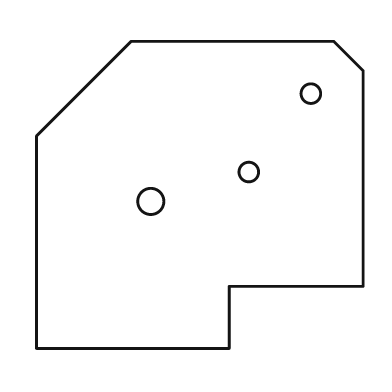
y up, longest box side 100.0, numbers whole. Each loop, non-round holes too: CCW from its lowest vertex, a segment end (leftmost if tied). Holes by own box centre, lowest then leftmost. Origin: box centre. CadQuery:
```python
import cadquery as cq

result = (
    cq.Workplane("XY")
    .moveTo(-50.0, -47.0)
    .lineTo(9.0, -47.0)
    .lineTo(9.0, -28.0)
    .lineTo(50.0, -28.0)
    .lineTo(50.0, 38.0)
    .lineTo(41.0, 47.0)
    .lineTo(-21.0, 47.0)
    .lineTo(-50.0, 18.0)
    .close()
    .moveTo(-15.0, -2.0)
    .circle(4.0)
    .moveTo(15.0, 7.0)
    .circle(3.0)
    .moveTo(34.0, 31.0)
    .circle(3.0)
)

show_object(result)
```